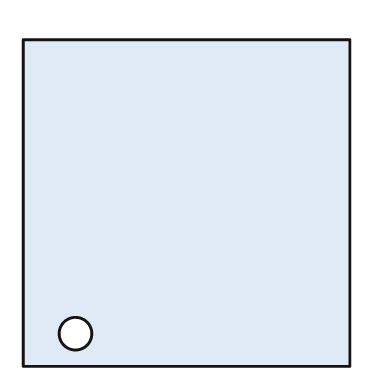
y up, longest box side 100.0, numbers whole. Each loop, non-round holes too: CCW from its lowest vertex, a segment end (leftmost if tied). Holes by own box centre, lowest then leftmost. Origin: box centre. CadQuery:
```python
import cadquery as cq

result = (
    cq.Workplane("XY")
    .moveTo(-50.0, -50.0)
    .lineTo(50.0, -50.0)
    .lineTo(50.0, 50.0)
    .lineTo(-50.0, 50.0)
    .close()
    .moveTo(-34.0, -40.0)
    .circle(5.0)
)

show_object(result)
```